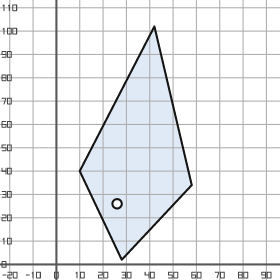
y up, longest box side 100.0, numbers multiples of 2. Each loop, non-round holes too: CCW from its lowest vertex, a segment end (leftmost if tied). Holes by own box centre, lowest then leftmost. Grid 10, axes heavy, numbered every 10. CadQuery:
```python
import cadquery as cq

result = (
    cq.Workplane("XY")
    .moveTo(28.0, 2.0)
    .lineTo(58.0, 34.0)
    .lineTo(42.0, 102.0)
    .lineTo(10.0, 40.0)
    .close()
    .moveTo(26.0, 26.0)
    .circle(2.0)
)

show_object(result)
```